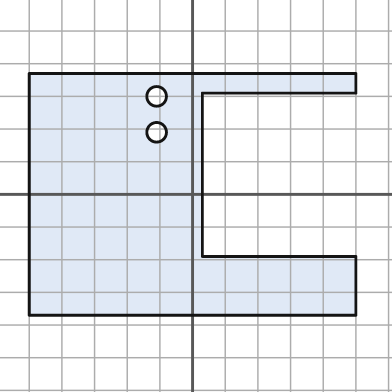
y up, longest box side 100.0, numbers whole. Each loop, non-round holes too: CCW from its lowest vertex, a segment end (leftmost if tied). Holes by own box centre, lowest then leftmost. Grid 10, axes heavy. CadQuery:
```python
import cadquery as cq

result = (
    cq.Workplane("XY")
    .moveTo(-50.0, -37.0)
    .lineTo(50.0, -37.0)
    .lineTo(50.0, -19.0)
    .lineTo(3.0, -19.0)
    .lineTo(3.0, 31.0)
    .lineTo(50.0, 31.0)
    .lineTo(50.0, 37.0)
    .lineTo(-50.0, 37.0)
    .close()
    .moveTo(-11.0, 19.0)
    .circle(3.0)
    .moveTo(-11.0, 30.0)
    .circle(3.0)
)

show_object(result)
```